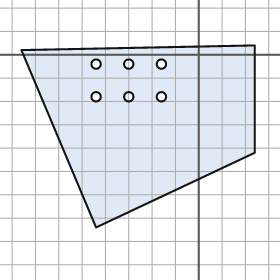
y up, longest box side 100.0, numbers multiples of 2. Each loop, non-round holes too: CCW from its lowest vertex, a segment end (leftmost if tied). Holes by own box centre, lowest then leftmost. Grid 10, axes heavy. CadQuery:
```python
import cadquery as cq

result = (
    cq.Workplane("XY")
    .moveTo(-44.0, -74.0)
    .lineTo(24.0, -42.0)
    .lineTo(24.0, 4.0)
    .lineTo(-76.0, 2.0)
    .close()
    .moveTo(-44.0, -18.0)
    .circle(2.0)
    .moveTo(-30.0, -18.0)
    .circle(2.0)
    .moveTo(-16.0, -18.0)
    .circle(2.0)
    .moveTo(-44.0, -4.0)
    .circle(2.0)
    .moveTo(-30.0, -4.0)
    .circle(2.0)
    .moveTo(-16.0, -4.0)
    .circle(2.0)
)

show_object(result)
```